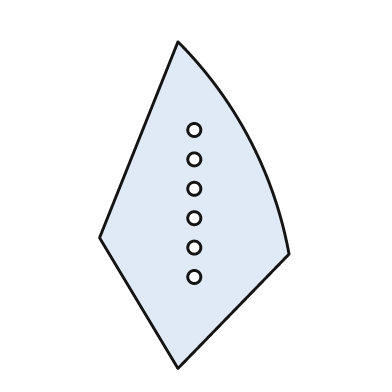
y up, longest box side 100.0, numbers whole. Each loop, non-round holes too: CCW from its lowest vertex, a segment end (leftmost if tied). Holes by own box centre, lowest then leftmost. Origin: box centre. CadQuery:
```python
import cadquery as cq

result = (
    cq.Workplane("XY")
    .moveTo(-5.0, -50.0)
    .lineTo(29.0, -15.0)
    .threePointArc((17.0, 20.0), (-5.0, 50.0))
    .lineTo(-29.0, -10.0)
    .close()
    .moveTo(0.0, -22.0)
    .circle(2.0)
    .moveTo(0.0, -13.0)
    .circle(2.0)
    .moveTo(0.0, -4.0)
    .circle(2.0)
    .moveTo(0.0, 5.0)
    .circle(2.0)
    .moveTo(0.0, 14.0)
    .circle(2.0)
    .moveTo(0.0, 23.0)
    .circle(2.0)
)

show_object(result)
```